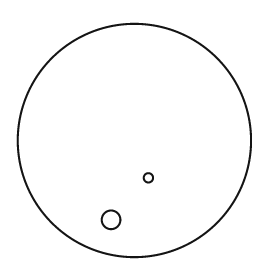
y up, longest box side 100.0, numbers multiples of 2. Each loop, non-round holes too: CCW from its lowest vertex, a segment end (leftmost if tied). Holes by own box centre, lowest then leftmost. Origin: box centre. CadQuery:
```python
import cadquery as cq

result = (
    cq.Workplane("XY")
    .moveTo(0.0, 0.0)
    .circle(50.0)
    .moveTo(-10.0, -34.0)
    .circle(4.0)
    .moveTo(6.0, -16.0)
    .circle(2.0)
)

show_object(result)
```